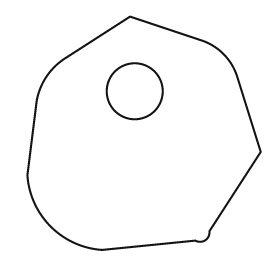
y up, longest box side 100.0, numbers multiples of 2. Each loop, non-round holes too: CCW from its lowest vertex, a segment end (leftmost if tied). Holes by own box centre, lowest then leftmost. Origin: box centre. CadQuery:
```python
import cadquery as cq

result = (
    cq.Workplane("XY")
    .moveTo(-18.0, -50.0)
    .lineTo(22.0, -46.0)
    .threePointArc((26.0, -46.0), (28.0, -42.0))
    .lineTo(50.0, -8.0)
    .lineTo(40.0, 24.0)
    .threePointArc((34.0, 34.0), (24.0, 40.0))
    .lineTo(-6.0, 50.0)
    .lineTo(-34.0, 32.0)
    .threePointArc((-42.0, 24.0), (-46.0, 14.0))
    .lineTo(-50.0, -18.0)
    .threePointArc((-40.0, -40.0), (-18.0, -50.0))
    .close()
    .moveTo(-4.0, 18.0)
    .circle(12.0)
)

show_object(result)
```